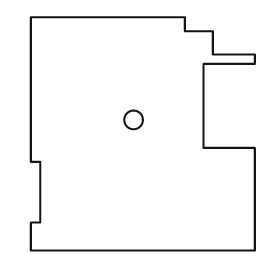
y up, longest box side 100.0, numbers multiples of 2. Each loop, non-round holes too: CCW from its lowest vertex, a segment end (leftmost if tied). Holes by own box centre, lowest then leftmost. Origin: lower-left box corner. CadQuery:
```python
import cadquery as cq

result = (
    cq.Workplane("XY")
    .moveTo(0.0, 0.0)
    .lineTo(96.0, 0.0)
    .lineTo(96.0, 44.0)
    .lineTo(74.0, 44.0)
    .lineTo(74.0, 80.0)
    .lineTo(96.0, 80.0)
    .lineTo(96.0, 84.0)
    .lineTo(78.0, 84.0)
    .lineTo(78.0, 94.0)
    .lineTo(66.0, 94.0)
    .lineTo(66.0, 100.0)
    .lineTo(0.0, 100.0)
    .lineTo(0.0, 38.0)
    .lineTo(4.0, 38.0)
    .lineTo(4.0, 12.0)
    .lineTo(0.0, 12.0)
    .close()
    .moveTo(44.0, 56.0)
    .circle(4.0)
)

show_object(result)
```